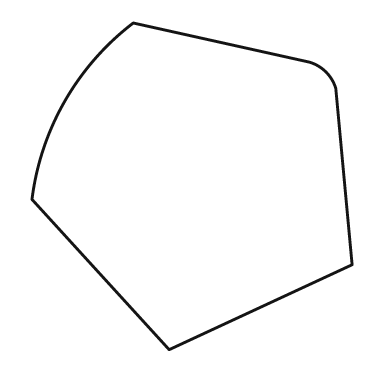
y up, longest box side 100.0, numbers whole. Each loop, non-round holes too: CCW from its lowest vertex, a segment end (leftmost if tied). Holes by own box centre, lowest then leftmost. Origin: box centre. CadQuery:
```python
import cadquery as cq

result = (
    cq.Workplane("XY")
    .moveTo(-7.0, -50.0)
    .lineTo(49.0, -24.0)
    .lineTo(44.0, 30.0)
    .threePointArc((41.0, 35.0), (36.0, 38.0))
    .lineTo(-18.0, 50.0)
    .threePointArc((-39.0, 26.0), (-49.0, -4.0))
    .close()
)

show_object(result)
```